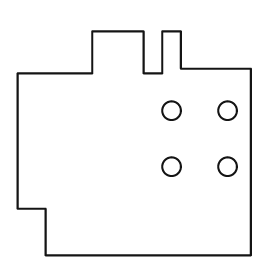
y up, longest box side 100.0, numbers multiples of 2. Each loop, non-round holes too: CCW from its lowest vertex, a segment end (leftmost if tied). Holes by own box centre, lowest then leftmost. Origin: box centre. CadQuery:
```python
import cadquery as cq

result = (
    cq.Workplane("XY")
    .moveTo(-38.0, -48.0)
    .lineTo(50.0, -48.0)
    .lineTo(50.0, 32.0)
    .lineTo(20.0, 32.0)
    .lineTo(20.0, 48.0)
    .lineTo(12.0, 48.0)
    .lineTo(12.0, 30.0)
    .lineTo(4.0, 30.0)
    .lineTo(4.0, 48.0)
    .lineTo(-18.0, 48.0)
    .lineTo(-18.0, 30.0)
    .lineTo(-50.0, 30.0)
    .lineTo(-50.0, -28.0)
    .lineTo(-38.0, -28.0)
    .close()
    .moveTo(16.0, -10.0)
    .circle(4.0)
    .moveTo(40.0, -10.0)
    .circle(4.0)
    .moveTo(16.0, 14.0)
    .circle(4.0)
    .moveTo(40.0, 14.0)
    .circle(4.0)
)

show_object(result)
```